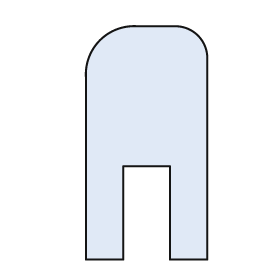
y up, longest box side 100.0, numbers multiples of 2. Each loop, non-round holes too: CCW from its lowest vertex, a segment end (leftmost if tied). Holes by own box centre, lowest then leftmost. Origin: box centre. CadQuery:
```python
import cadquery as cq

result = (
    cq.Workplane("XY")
    .moveTo(-26.0, -50.0)
    .lineTo(-10.0, -50.0)
    .lineTo(-10.0, -10.0)
    .lineTo(10.0, -10.0)
    .lineTo(10.0, -50.0)
    .lineTo(26.0, -50.0)
    .lineTo(26.0, 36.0)
    .threePointArc((22.0, 46.0), (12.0, 50.0))
    .lineTo(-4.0, 50.0)
    .threePointArc((-20.0, 44.0), (-26.0, 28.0))
    .close()
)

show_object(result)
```